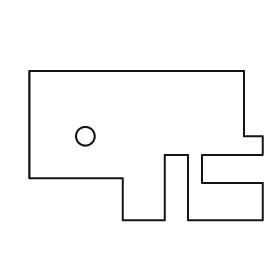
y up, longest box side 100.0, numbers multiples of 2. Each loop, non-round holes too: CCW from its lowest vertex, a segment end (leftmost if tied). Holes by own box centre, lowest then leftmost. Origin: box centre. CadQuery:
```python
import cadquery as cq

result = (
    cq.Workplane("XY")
    .moveTo(-10.0, -32.0)
    .lineTo(8.0, -32.0)
    .lineTo(8.0, -4.0)
    .lineTo(18.0, -4.0)
    .lineTo(18.0, -32.0)
    .lineTo(50.0, -32.0)
    .lineTo(50.0, -16.0)
    .lineTo(24.0, -16.0)
    .lineTo(24.0, -4.0)
    .lineTo(50.0, -4.0)
    .lineTo(50.0, 4.0)
    .lineTo(42.0, 4.0)
    .lineTo(42.0, 32.0)
    .lineTo(-50.0, 32.0)
    .lineTo(-50.0, -14.0)
    .lineTo(-10.0, -14.0)
    .close()
    .moveTo(-26.0, 4.0)
    .circle(4.0)
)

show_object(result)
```